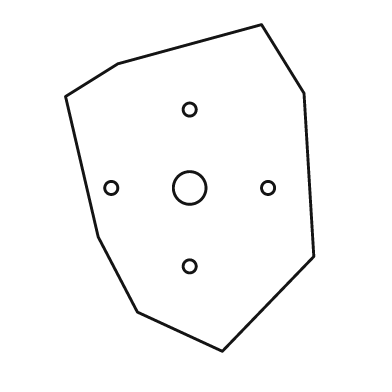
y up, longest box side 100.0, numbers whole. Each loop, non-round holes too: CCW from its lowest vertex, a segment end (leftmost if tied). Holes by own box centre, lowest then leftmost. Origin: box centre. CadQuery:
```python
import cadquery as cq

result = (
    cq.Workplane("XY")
    .moveTo(10.0, -50.0)
    .lineTo(38.0, -21.0)
    .lineTo(35.0, 29.0)
    .lineTo(22.0, 50.0)
    .lineTo(-22.0, 38.0)
    .lineTo(-38.0, 28.0)
    .lineTo(-28.0, -15.0)
    .lineTo(-16.0, -38.0)
    .close()
    .moveTo(0.0, -24.0)
    .circle(2.0)
    .moveTo(-24.0, 0.0)
    .circle(2.0)
    .moveTo(0.0, 0.0)
    .circle(5.0)
    .moveTo(24.0, 0.0)
    .circle(2.0)
    .moveTo(0.0, 24.0)
    .circle(2.0)
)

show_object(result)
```